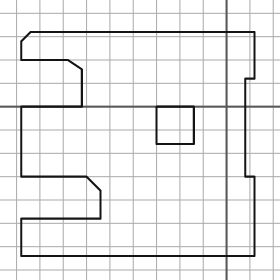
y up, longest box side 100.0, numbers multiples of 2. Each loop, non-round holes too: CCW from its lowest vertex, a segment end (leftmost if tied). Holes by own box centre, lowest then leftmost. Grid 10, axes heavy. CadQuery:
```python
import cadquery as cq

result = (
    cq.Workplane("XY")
    .moveTo(-88.0, -64.0)
    .lineTo(12.0, -64.0)
    .lineTo(12.0, -30.0)
    .lineTo(8.0, -30.0)
    .lineTo(8.0, 12.0)
    .lineTo(12.0, 12.0)
    .lineTo(12.0, 32.0)
    .lineTo(-84.0, 32.0)
    .lineTo(-88.0, 28.0)
    .lineTo(-88.0, 20.0)
    .lineTo(-68.0, 20.0)
    .lineTo(-62.0, 16.0)
    .lineTo(-62.0, 0.0)
    .lineTo(-88.0, 0.0)
    .lineTo(-88.0, -30.0)
    .lineTo(-60.0, -30.0)
    .lineTo(-54.0, -36.0)
    .lineTo(-54.0, -48.0)
    .lineTo(-88.0, -48.0)
    .close()
    .moveTo(-30.0, -16.0)
    .lineTo(-14.0, -16.0)
    .lineTo(-14.0, 0.0)
    .lineTo(-30.0, 0.0)
    .close()
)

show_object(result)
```